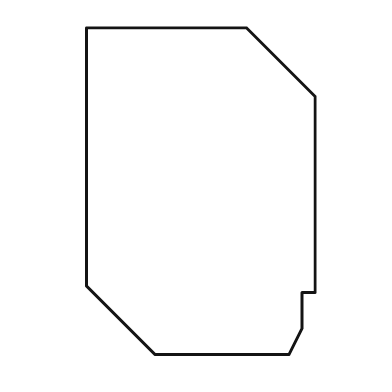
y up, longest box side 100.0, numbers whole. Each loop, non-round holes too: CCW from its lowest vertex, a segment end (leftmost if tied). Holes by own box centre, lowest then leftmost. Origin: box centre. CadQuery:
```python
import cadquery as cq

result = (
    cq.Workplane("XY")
    .moveTo(-14.0, -50.0)
    .lineTo(27.0, -50.0)
    .lineTo(31.0, -42.0)
    .lineTo(31.0, -31.0)
    .lineTo(35.0, -31.0)
    .lineTo(35.0, 29.0)
    .lineTo(14.0, 50.0)
    .lineTo(-35.0, 50.0)
    .lineTo(-35.0, -29.0)
    .close()
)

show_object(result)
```